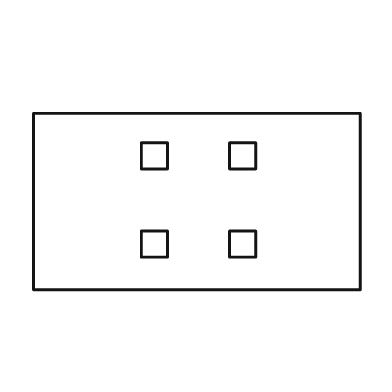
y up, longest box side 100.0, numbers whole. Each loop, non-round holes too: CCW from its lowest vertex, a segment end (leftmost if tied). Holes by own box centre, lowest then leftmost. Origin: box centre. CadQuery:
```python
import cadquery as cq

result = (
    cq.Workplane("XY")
    .moveTo(-50.0, -27.0)
    .lineTo(50.0, -27.0)
    .lineTo(50.0, 27.0)
    .lineTo(-50.0, 27.0)
    .close()
    .moveTo(-17.0, -17.0)
    .lineTo(-9.0, -17.0)
    .lineTo(-9.0, -9.0)
    .lineTo(-17.0, -9.0)
    .close()
    .moveTo(10.0, -17.0)
    .lineTo(18.0, -17.0)
    .lineTo(18.0, -9.0)
    .lineTo(10.0, -9.0)
    .close()
    .moveTo(-17.0, 10.0)
    .lineTo(-9.0, 10.0)
    .lineTo(-9.0, 18.0)
    .lineTo(-17.0, 18.0)
    .close()
    .moveTo(10.0, 10.0)
    .lineTo(18.0, 10.0)
    .lineTo(18.0, 18.0)
    .lineTo(10.0, 18.0)
    .close()
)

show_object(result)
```